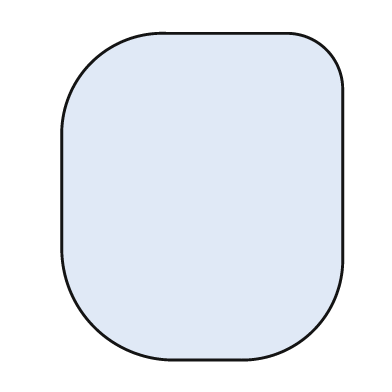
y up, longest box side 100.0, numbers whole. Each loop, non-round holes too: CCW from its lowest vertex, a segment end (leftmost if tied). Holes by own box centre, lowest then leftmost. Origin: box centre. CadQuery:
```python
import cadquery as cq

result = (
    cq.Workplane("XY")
    .moveTo(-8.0, -50.0)
    .lineTo(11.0, -50.0)
    .threePointArc((34.0, -41.0), (43.0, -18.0))
    .lineTo(43.0, 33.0)
    .threePointArc((38.0, 45.0), (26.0, 50.0))
    .lineTo(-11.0, 50.0)
    .threePointArc((-34.0, 41.0), (-43.0, 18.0))
    .lineTo(-43.0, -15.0)
    .threePointArc((-33.0, -40.0), (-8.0, -50.0))
    .close()
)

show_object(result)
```